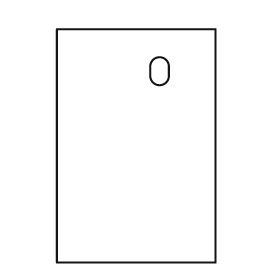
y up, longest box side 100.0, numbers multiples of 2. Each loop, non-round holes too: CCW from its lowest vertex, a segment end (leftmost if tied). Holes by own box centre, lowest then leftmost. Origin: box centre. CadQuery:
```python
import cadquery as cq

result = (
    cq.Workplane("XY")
    .moveTo(-34.0, -50.0)
    .lineTo(34.0, -50.0)
    .lineTo(34.0, 50.0)
    .lineTo(-34.0, 50.0)
    .close()
    .moveTo(6.0, 30.0)
    .threePointArc((10.0, 26.0), (14.0, 30.0))
    .lineTo(14.0, 34.0)
    .threePointArc((10.0, 38.0), (6.0, 34.0))
    .close()
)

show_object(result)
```